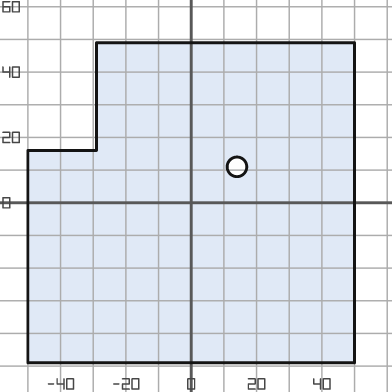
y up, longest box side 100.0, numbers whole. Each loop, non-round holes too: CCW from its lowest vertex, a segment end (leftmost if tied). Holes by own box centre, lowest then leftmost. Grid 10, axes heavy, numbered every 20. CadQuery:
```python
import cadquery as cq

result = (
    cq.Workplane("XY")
    .moveTo(-50.0, -49.0)
    .lineTo(50.0, -49.0)
    .lineTo(50.0, 49.0)
    .lineTo(-29.0, 49.0)
    .lineTo(-29.0, 16.0)
    .lineTo(-50.0, 16.0)
    .close()
    .moveTo(14.0, 11.0)
    .circle(3.0)
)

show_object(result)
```